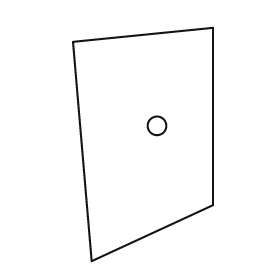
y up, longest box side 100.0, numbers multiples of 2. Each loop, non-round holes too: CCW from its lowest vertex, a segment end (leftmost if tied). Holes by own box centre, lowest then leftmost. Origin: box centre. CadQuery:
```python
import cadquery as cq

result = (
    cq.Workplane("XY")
    .moveTo(-22.0, -50.0)
    .lineTo(30.0, -26.0)
    .lineTo(30.0, 50.0)
    .lineTo(-30.0, 44.0)
    .close()
    .moveTo(6.0, 8.0)
    .circle(4.0)
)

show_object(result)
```